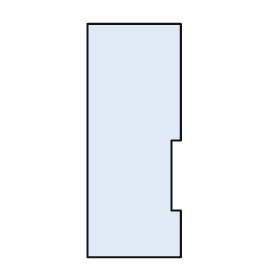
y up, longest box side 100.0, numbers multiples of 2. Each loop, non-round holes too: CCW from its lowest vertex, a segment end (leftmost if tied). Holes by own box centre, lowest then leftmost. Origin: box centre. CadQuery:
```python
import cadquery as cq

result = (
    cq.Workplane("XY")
    .moveTo(-20.0, -50.0)
    .lineTo(20.0, -50.0)
    .lineTo(20.0, -30.0)
    .lineTo(16.0, -30.0)
    .lineTo(16.0, 0.0)
    .lineTo(20.0, 0.0)
    .lineTo(20.0, 50.0)
    .lineTo(-20.0, 50.0)
    .close()
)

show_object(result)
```